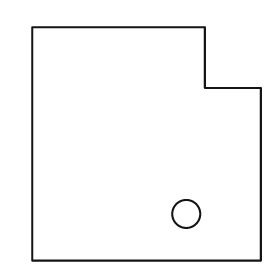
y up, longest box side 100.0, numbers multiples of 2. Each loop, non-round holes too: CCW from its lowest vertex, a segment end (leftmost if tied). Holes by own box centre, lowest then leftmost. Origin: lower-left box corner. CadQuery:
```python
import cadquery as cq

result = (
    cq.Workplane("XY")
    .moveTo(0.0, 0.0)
    .lineTo(98.0, 0.0)
    .lineTo(98.0, 74.0)
    .lineTo(74.0, 74.0)
    .lineTo(74.0, 100.0)
    .lineTo(0.0, 100.0)
    .close()
    .moveTo(66.0, 20.0)
    .circle(6.0)
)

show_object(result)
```